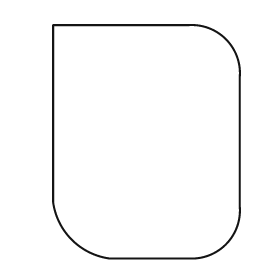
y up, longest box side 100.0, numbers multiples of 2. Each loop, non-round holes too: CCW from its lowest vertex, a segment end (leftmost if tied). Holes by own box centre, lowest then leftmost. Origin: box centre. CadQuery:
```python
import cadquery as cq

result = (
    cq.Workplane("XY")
    .moveTo(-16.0, -50.0)
    .lineTo(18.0, -50.0)
    .threePointArc((34.0, -44.0), (40.0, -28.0))
    .lineTo(40.0, 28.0)
    .threePointArc((34.0, 44.0), (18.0, 50.0))
    .lineTo(-40.0, 50.0)
    .lineTo(-40.0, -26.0)
    .threePointArc((-32.0, -42.0), (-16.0, -50.0))
    .close()
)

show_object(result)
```